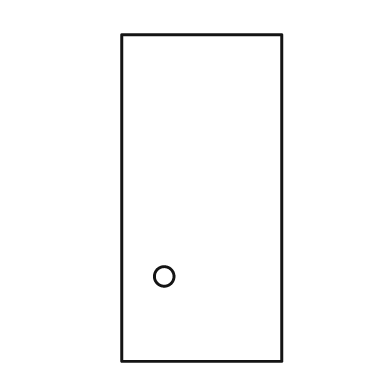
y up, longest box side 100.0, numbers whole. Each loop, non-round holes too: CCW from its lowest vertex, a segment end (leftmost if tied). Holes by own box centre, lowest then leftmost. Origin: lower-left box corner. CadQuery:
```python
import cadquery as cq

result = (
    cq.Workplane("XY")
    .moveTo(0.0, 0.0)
    .lineTo(49.0, 0.0)
    .lineTo(49.0, 100.0)
    .lineTo(0.0, 100.0)
    .close()
    .moveTo(13.0, 26.0)
    .circle(3.0)
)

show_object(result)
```